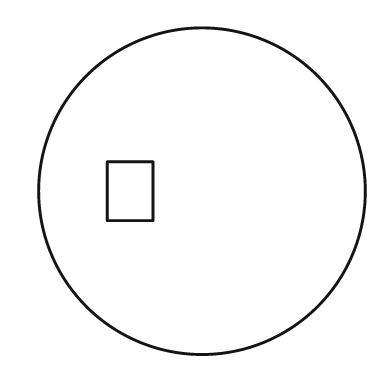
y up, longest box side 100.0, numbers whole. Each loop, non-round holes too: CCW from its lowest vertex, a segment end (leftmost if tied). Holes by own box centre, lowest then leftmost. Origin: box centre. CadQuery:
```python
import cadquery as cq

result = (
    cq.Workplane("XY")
    .moveTo(0.0, 0.0)
    .circle(50.0)
    .moveTo(-29.0, -9.0)
    .lineTo(-15.0, -9.0)
    .lineTo(-15.0, 9.0)
    .lineTo(-29.0, 9.0)
    .close()
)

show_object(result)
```